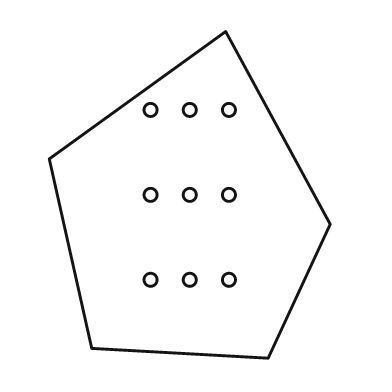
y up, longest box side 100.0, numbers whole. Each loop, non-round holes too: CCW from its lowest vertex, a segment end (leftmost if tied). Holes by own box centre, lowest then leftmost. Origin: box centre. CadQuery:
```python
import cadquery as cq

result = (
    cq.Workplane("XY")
    .moveTo(24.0, -50.0)
    .lineTo(43.0, -9.0)
    .lineTo(11.0, 50.0)
    .lineTo(-43.0, 11.0)
    .lineTo(-30.0, -47.0)
    .close()
    .moveTo(-12.0, -26.0)
    .circle(2.0)
    .moveTo(0.0, -26.0)
    .circle(2.0)
    .moveTo(12.0, -26.0)
    .circle(2.0)
    .moveTo(-12.0, 0.0)
    .circle(2.0)
    .moveTo(0.0, 0.0)
    .circle(2.0)
    .moveTo(12.0, 0.0)
    .circle(2.0)
    .moveTo(-12.0, 26.0)
    .circle(2.0)
    .moveTo(0.0, 26.0)
    .circle(2.0)
    .moveTo(12.0, 26.0)
    .circle(2.0)
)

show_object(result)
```